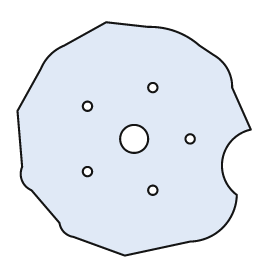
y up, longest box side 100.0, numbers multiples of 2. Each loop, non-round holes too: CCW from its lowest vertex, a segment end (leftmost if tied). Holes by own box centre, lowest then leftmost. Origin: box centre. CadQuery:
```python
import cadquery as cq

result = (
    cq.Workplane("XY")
    .moveTo(-4.0, -50.0)
    .lineTo(24.0, -44.0)
    .threePointArc((38.0, -38.0), (44.0, -24.0))
    .threePointArc((38.0, -8.0), (50.0, 4.0))
    .lineTo(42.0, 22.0)
    .threePointArc((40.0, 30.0), (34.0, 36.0))
    .lineTo(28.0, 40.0)
    .threePointArc((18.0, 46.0), (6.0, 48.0))
    .lineTo(-12.0, 50.0)
    .lineTo(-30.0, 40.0)
    .threePointArc((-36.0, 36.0), (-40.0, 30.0))
    .lineTo(-50.0, 12.0)
    .lineTo(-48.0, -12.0)
    .threePointArc((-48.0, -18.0), (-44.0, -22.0))
    .lineTo(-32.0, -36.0)
    .threePointArc((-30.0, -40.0), (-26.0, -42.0))
    .close()
    .moveTo(8.0, -22.0)
    .circle(2.0)
    .moveTo(-20.0, -14.0)
    .circle(2.0)
    .moveTo(0.0, 0.0)
    .circle(6.0)
    .moveTo(24.0, 0.0)
    .circle(2.0)
    .moveTo(-20.0, 14.0)
    .circle(2.0)
    .moveTo(8.0, 22.0)
    .circle(2.0)
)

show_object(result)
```